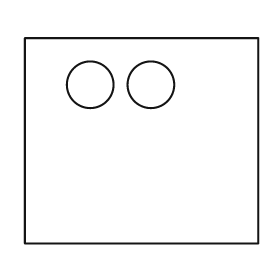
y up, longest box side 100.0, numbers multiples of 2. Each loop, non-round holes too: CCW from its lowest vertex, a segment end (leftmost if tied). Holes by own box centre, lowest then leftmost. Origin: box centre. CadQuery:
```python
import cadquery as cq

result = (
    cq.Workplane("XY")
    .moveTo(-50.0, -44.0)
    .lineTo(50.0, -44.0)
    .lineTo(50.0, 44.0)
    .lineTo(-50.0, 44.0)
    .close()
    .moveTo(-22.0, 24.0)
    .circle(10.0)
    .moveTo(4.0, 24.0)
    .circle(10.0)
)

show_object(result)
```